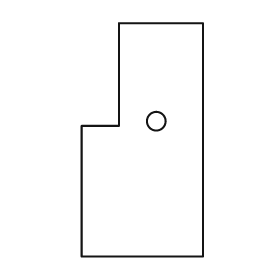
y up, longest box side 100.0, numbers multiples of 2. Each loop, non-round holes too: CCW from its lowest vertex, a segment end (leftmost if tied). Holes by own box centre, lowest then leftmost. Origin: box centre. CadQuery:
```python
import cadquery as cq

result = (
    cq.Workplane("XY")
    .moveTo(-26.0, -50.0)
    .lineTo(26.0, -50.0)
    .lineTo(26.0, 50.0)
    .lineTo(-10.0, 50.0)
    .lineTo(-10.0, 6.0)
    .lineTo(-26.0, 6.0)
    .close()
    .moveTo(6.0, 8.0)
    .circle(4.0)
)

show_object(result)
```